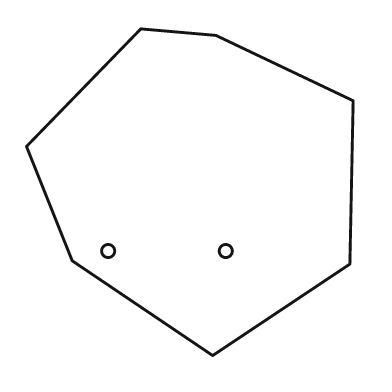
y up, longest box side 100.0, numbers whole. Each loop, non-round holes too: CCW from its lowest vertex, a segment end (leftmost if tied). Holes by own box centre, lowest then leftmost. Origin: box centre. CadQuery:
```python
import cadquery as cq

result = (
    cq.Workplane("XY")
    .moveTo(7.0, -50.0)
    .lineTo(49.0, -22.0)
    .lineTo(50.0, 28.0)
    .lineTo(8.0, 48.0)
    .lineTo(-15.0, 50.0)
    .lineTo(-50.0, 14.0)
    .lineTo(-36.0, -21.0)
    .close()
    .moveTo(-25.0, -18.0)
    .circle(2.0)
    .moveTo(11.0, -18.0)
    .circle(2.0)
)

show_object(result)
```